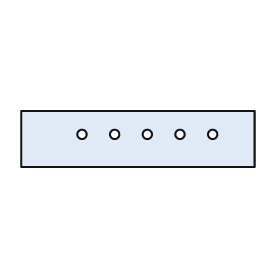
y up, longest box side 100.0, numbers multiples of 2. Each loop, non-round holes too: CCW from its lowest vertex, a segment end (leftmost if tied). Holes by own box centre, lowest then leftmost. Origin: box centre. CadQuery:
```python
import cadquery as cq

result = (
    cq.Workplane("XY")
    .moveTo(-50.0, -12.0)
    .lineTo(50.0, -12.0)
    .lineTo(50.0, 12.0)
    .lineTo(-50.0, 12.0)
    .close()
    .moveTo(-24.0, 2.0)
    .circle(2.0)
    .moveTo(-10.0, 2.0)
    .circle(2.0)
    .moveTo(4.0, 2.0)
    .circle(2.0)
    .moveTo(18.0, 2.0)
    .circle(2.0)
    .moveTo(32.0, 2.0)
    .circle(2.0)
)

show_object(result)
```